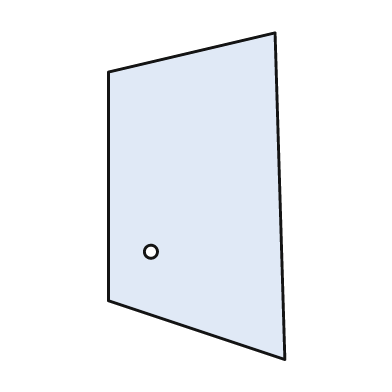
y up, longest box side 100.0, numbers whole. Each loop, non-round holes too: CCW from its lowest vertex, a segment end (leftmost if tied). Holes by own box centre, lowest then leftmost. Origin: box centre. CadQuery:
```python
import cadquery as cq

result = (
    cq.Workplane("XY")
    .moveTo(27.0, -50.0)
    .lineTo(24.0, 50.0)
    .lineTo(-27.0, 38.0)
    .lineTo(-27.0, -32.0)
    .close()
    .moveTo(-14.0, -17.0)
    .circle(2.0)
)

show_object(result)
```